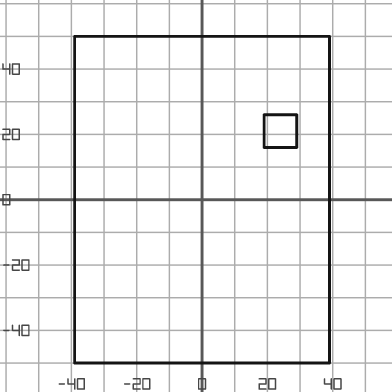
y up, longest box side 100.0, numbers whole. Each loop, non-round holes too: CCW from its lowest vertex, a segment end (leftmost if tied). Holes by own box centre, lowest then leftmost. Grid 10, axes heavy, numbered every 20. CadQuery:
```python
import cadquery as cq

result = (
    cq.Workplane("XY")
    .moveTo(-39.0, -50.0)
    .lineTo(39.0, -50.0)
    .lineTo(39.0, 50.0)
    .lineTo(-39.0, 50.0)
    .close()
    .moveTo(19.0, 16.0)
    .lineTo(29.0, 16.0)
    .lineTo(29.0, 26.0)
    .lineTo(19.0, 26.0)
    .close()
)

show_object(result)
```